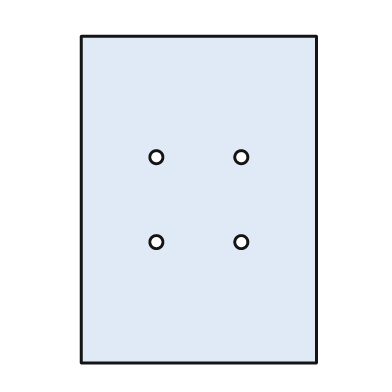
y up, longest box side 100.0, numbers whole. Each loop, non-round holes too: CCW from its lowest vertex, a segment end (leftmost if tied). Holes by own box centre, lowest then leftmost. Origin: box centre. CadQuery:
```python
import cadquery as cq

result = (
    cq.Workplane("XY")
    .moveTo(-36.0, -50.0)
    .lineTo(36.0, -50.0)
    .lineTo(36.0, 50.0)
    .lineTo(-36.0, 50.0)
    .close()
    .moveTo(-13.0, -13.0)
    .circle(2.0)
    .moveTo(13.0, -13.0)
    .circle(2.0)
    .moveTo(-13.0, 13.0)
    .circle(2.0)
    .moveTo(13.0, 13.0)
    .circle(2.0)
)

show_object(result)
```